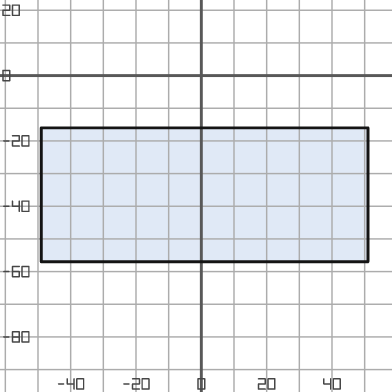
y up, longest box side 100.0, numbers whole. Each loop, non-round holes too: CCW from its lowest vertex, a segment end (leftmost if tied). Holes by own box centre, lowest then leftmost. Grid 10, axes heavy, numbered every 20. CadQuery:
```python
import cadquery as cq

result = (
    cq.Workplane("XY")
    .moveTo(-49.0, -57.0)
    .lineTo(51.0, -57.0)
    .lineTo(51.0, -16.0)
    .lineTo(-49.0, -16.0)
    .close()
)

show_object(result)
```